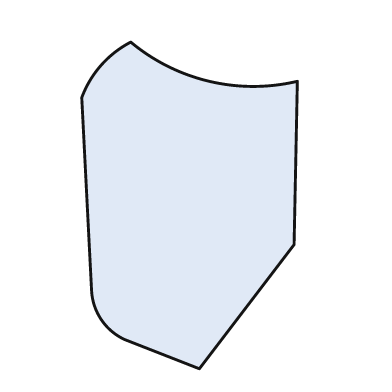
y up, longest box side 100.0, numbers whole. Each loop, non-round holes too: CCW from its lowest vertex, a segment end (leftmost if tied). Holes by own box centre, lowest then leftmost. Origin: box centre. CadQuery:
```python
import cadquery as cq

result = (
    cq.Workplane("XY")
    .moveTo(3.0, -50.0)
    .lineTo(32.0, -12.0)
    .lineTo(33.0, 38.0)
    .threePointArc((6.0, 38.0), (-18.0, 50.0))
    .threePointArc((-27.0, 43.0), (-33.0, 33.0))
    .lineTo(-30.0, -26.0)
    .threePointArc((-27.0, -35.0), (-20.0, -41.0))
    .close()
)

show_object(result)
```